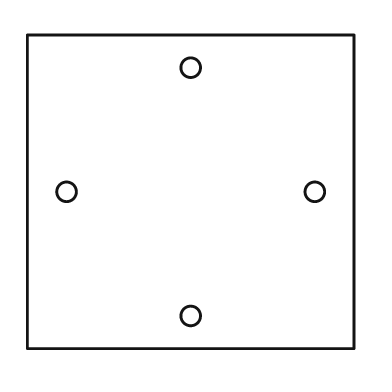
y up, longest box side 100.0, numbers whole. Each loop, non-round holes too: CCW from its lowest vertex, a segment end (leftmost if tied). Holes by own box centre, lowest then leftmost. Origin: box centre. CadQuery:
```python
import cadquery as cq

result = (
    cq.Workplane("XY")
    .moveTo(-50.0, -48.0)
    .lineTo(50.0, -48.0)
    .lineTo(50.0, 48.0)
    .lineTo(-50.0, 48.0)
    .close()
    .moveTo(0.0, -38.0)
    .circle(3.0)
    .moveTo(-38.0, 0.0)
    .circle(3.0)
    .moveTo(38.0, 0.0)
    .circle(3.0)
    .moveTo(0.0, 38.0)
    .circle(3.0)
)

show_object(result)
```